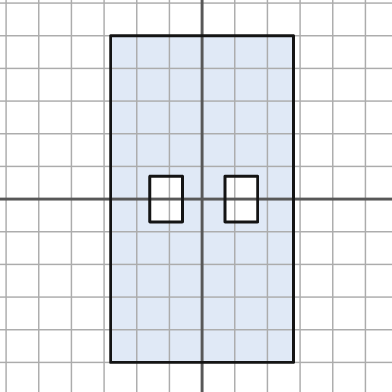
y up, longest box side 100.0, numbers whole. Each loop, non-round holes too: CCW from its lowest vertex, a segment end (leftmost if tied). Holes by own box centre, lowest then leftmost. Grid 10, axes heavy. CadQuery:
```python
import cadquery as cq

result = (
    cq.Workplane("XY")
    .moveTo(-28.0, -50.0)
    .lineTo(28.0, -50.0)
    .lineTo(28.0, 50.0)
    .lineTo(-28.0, 50.0)
    .close()
    .moveTo(-16.0, -7.0)
    .lineTo(-6.0, -7.0)
    .lineTo(-6.0, 7.0)
    .lineTo(-16.0, 7.0)
    .close()
    .moveTo(7.0, -7.0)
    .lineTo(17.0, -7.0)
    .lineTo(17.0, 7.0)
    .lineTo(7.0, 7.0)
    .close()
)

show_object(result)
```